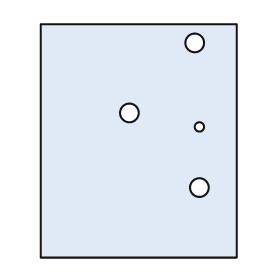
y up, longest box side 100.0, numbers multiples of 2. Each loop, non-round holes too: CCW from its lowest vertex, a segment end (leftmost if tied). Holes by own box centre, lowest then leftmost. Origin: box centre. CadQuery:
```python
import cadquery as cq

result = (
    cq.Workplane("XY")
    .moveTo(-42.0, -50.0)
    .lineTo(42.0, -50.0)
    .lineTo(42.0, 50.0)
    .lineTo(-42.0, 50.0)
    .close()
    .moveTo(26.0, -20.0)
    .circle(4.0)
    .moveTo(26.0, 6.0)
    .circle(2.0)
    .moveTo(-4.0, 12.0)
    .circle(4.0)
    .moveTo(24.0, 42.0)
    .circle(4.0)
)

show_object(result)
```